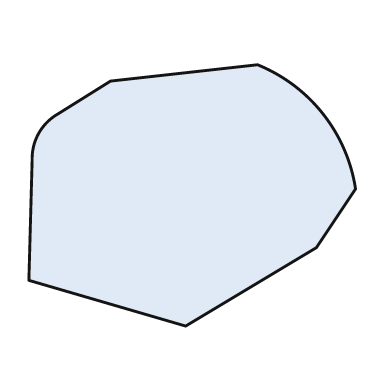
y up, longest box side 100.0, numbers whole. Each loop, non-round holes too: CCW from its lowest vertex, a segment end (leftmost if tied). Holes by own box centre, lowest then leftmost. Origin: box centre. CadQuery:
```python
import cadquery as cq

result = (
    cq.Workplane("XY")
    .moveTo(-2.0, -40.0)
    .lineTo(38.0, -16.0)
    .lineTo(50.0, 2.0)
    .threePointArc((40.0, 25.0), (20.0, 40.0))
    .lineTo(-25.0, 35.0)
    .lineTo(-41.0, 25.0)
    .threePointArc((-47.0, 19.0), (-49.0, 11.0))
    .lineTo(-50.0, -26.0)
    .close()
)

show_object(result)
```